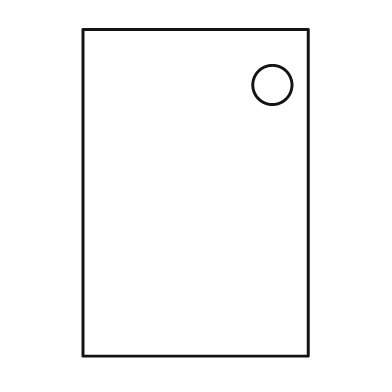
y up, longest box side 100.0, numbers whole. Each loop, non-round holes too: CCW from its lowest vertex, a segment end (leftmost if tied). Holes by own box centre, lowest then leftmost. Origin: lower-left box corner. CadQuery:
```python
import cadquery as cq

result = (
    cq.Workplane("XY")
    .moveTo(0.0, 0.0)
    .lineTo(69.0, 0.0)
    .lineTo(69.0, 100.0)
    .lineTo(0.0, 100.0)
    .close()
    .moveTo(58.0, 83.0)
    .circle(6.0)
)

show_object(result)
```